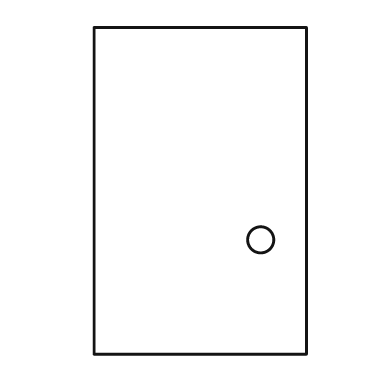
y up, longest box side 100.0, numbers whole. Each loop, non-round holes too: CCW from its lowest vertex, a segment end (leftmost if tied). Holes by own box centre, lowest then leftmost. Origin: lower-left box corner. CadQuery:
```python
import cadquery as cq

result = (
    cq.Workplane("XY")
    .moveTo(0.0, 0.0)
    .lineTo(65.0, 0.0)
    .lineTo(65.0, 100.0)
    .lineTo(0.0, 100.0)
    .close()
    .moveTo(51.0, 35.0)
    .circle(4.0)
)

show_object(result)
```